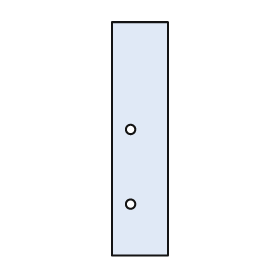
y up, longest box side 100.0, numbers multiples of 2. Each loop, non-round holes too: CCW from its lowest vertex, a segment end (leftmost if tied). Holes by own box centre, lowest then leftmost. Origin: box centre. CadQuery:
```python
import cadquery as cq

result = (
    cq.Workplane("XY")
    .moveTo(-12.0, -50.0)
    .lineTo(12.0, -50.0)
    .lineTo(12.0, 50.0)
    .lineTo(-12.0, 50.0)
    .close()
    .moveTo(-4.0, -28.0)
    .circle(2.0)
    .moveTo(-4.0, 4.0)
    .circle(2.0)
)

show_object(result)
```